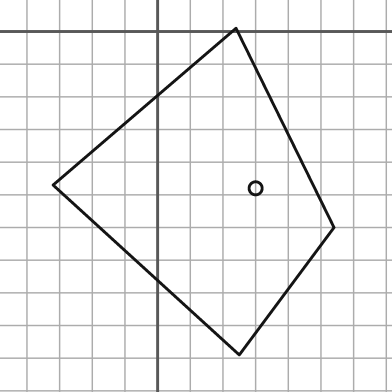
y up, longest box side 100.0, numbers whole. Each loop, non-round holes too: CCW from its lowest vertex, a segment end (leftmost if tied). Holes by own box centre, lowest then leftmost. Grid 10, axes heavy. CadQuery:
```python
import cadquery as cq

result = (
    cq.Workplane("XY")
    .moveTo(25.0, -99.0)
    .lineTo(54.0, -60.0)
    .lineTo(24.0, 1.0)
    .lineTo(-32.0, -47.0)
    .close()
    .moveTo(30.0, -48.0)
    .circle(2.0)
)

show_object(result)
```